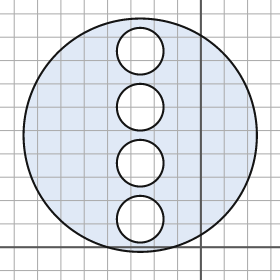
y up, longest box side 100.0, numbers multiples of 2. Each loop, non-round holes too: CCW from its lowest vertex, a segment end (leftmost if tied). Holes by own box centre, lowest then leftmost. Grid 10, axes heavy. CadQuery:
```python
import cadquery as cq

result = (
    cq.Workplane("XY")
    .moveTo(-26.0, 48.0)
    .circle(50.0)
    .moveTo(-26.0, 12.0)
    .circle(10.0)
    .moveTo(-26.0, 36.0)
    .circle(10.0)
    .moveTo(-26.0, 60.0)
    .circle(10.0)
    .moveTo(-26.0, 84.0)
    .circle(10.0)
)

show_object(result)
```